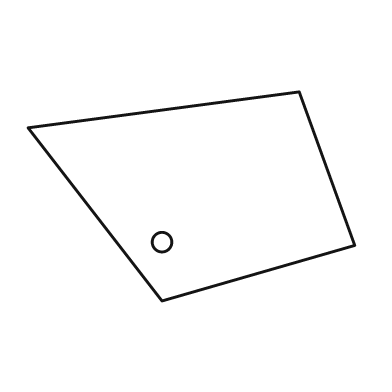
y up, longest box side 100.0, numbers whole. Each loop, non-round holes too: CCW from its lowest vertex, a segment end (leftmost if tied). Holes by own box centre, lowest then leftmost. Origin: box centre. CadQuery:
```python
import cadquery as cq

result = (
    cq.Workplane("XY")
    .moveTo(-9.0, -32.0)
    .lineTo(50.0, -15.0)
    .lineTo(33.0, 32.0)
    .lineTo(-50.0, 21.0)
    .close()
    .moveTo(-9.0, -14.0)
    .circle(3.0)
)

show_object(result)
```